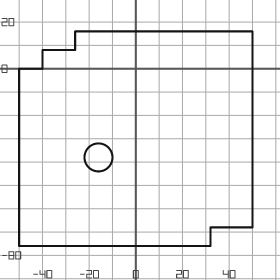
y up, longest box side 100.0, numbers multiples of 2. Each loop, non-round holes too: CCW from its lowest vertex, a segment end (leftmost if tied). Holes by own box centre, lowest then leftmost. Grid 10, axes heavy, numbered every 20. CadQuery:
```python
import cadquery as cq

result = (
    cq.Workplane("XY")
    .moveTo(-50.0, -76.0)
    .lineTo(32.0, -76.0)
    .lineTo(32.0, -68.0)
    .lineTo(50.0, -68.0)
    .lineTo(50.0, 16.0)
    .lineTo(-26.0, 16.0)
    .lineTo(-26.0, 8.0)
    .lineTo(-40.0, 8.0)
    .lineTo(-40.0, 0.0)
    .lineTo(-50.0, 0.0)
    .close()
    .moveTo(-16.0, -38.0)
    .circle(6.0)
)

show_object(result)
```